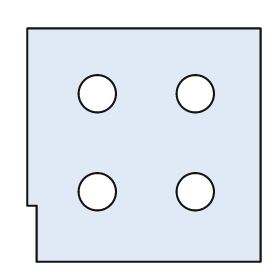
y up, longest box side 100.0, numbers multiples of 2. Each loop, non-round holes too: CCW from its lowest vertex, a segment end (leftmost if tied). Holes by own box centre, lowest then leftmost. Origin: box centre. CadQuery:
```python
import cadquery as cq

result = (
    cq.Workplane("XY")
    .moveTo(-46.0, -50.0)
    .lineTo(50.0, -50.0)
    .lineTo(50.0, 50.0)
    .lineTo(-50.0, 50.0)
    .lineTo(-50.0, -26.0)
    .lineTo(-46.0, -26.0)
    .close()
    .moveTo(-20.0, -20.0)
    .circle(8.0)
    .moveTo(22.0, -20.0)
    .circle(8.0)
    .moveTo(-20.0, 22.0)
    .circle(8.0)
    .moveTo(22.0, 22.0)
    .circle(8.0)
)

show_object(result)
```